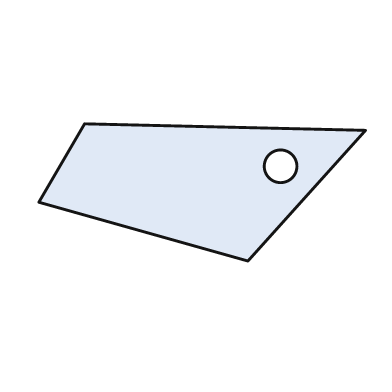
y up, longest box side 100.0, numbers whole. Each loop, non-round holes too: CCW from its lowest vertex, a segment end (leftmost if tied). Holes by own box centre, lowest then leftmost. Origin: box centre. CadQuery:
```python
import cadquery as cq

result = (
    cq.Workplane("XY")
    .moveTo(14.0, -21.0)
    .lineTo(50.0, 19.0)
    .lineTo(-36.0, 21.0)
    .lineTo(-50.0, -3.0)
    .close()
    .moveTo(24.0, 8.0)
    .circle(5.0)
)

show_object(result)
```